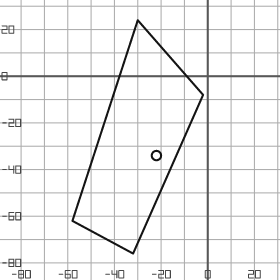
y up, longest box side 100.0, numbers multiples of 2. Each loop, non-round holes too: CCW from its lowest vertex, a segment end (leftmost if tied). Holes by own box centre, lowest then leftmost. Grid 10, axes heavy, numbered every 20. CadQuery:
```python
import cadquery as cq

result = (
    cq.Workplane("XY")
    .moveTo(-32.0, -76.0)
    .lineTo(-2.0, -8.0)
    .lineTo(-30.0, 24.0)
    .lineTo(-58.0, -62.0)
    .close()
    .moveTo(-22.0, -34.0)
    .circle(2.0)
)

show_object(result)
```